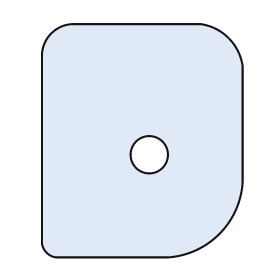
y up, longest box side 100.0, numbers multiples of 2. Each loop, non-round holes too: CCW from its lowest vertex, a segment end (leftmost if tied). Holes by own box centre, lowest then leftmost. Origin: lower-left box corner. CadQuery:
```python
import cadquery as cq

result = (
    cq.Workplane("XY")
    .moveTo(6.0, 0.0)
    .lineTo(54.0, 0.0)
    .threePointArc((76.0, 10.0), (86.0, 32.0))
    .lineTo(86.0, 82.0)
    .threePointArc((80.0, 94.0), (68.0, 100.0))
    .lineTo(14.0, 100.0)
    .threePointArc((4.0, 96.0), (0.0, 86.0))
    .lineTo(0.0, 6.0)
    .threePointArc((2.0, 2.0), (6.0, 0.0))
    .close()
    .moveTo(46.0, 44.0)
    .circle(8.0)
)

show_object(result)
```